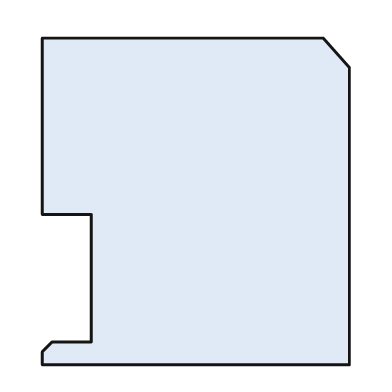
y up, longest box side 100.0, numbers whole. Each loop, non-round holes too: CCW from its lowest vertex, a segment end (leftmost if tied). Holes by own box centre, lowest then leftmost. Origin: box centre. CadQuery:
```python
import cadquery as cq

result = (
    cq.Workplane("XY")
    .moveTo(-47.0, -50.0)
    .lineTo(47.0, -50.0)
    .lineTo(47.0, 41.0)
    .lineTo(39.0, 50.0)
    .lineTo(-47.0, 50.0)
    .lineTo(-47.0, -4.0)
    .lineTo(-32.0, -4.0)
    .lineTo(-32.0, -43.0)
    .lineTo(-44.0, -43.0)
    .lineTo(-47.0, -46.0)
    .close()
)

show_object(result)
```